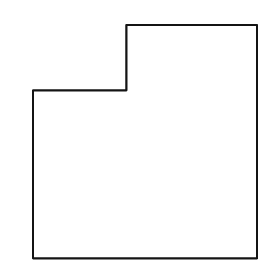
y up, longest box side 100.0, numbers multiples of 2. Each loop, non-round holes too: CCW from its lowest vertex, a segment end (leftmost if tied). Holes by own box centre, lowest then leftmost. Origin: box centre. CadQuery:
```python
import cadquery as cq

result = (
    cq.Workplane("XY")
    .moveTo(-48.0, -50.0)
    .lineTo(48.0, -50.0)
    .lineTo(48.0, 50.0)
    .lineTo(-8.0, 50.0)
    .lineTo(-8.0, 22.0)
    .lineTo(-48.0, 22.0)
    .close()
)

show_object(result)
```